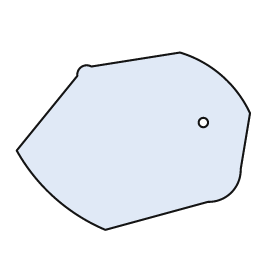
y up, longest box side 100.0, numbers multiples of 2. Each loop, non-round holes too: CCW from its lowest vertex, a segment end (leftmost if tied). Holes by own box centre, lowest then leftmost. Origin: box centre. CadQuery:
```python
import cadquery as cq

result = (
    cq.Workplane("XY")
    .moveTo(-12.0, -38.0)
    .lineTo(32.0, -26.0)
    .threePointArc((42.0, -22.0), (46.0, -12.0))
    .lineTo(50.0, 12.0)
    .threePointArc((38.0, 28.0), (20.0, 38.0))
    .lineTo(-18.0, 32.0)
    .threePointArc((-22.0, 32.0), (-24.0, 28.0))
    .lineTo(-50.0, -4.0)
    .threePointArc((-34.0, -24.0), (-12.0, -38.0))
    .close()
    .moveTo(30.0, 8.0)
    .circle(2.0)
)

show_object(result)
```